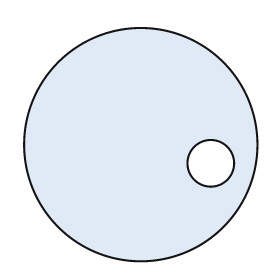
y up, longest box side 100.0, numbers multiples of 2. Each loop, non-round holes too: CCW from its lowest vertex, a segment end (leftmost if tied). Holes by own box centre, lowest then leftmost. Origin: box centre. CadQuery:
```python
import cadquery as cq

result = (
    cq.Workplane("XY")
    .moveTo(0.0, 0.0)
    .circle(50.0)
    .moveTo(30.0, -8.0)
    .circle(10.0)
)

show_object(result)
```